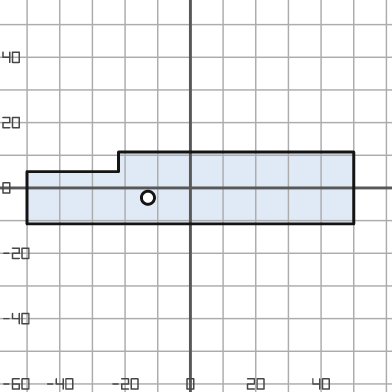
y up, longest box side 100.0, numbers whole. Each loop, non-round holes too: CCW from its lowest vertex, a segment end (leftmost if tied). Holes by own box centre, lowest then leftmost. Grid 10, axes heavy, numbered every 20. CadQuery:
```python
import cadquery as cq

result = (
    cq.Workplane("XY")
    .moveTo(-50.0, -11.0)
    .lineTo(50.0, -11.0)
    .lineTo(50.0, 11.0)
    .lineTo(-22.0, 11.0)
    .lineTo(-22.0, 5.0)
    .lineTo(-50.0, 5.0)
    .close()
    .moveTo(-13.0, -3.0)
    .circle(2.0)
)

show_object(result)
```